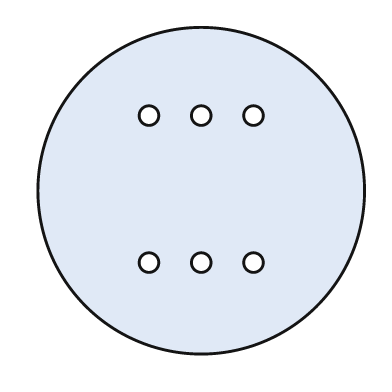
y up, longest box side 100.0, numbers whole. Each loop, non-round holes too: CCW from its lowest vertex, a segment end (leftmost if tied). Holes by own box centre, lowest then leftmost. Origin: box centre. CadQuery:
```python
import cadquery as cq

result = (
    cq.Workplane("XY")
    .moveTo(0.0, 0.0)
    .circle(50.0)
    .moveTo(-16.0, -22.0)
    .circle(3.0)
    .moveTo(0.0, -22.0)
    .circle(3.0)
    .moveTo(16.0, -22.0)
    .circle(3.0)
    .moveTo(-16.0, 23.0)
    .circle(3.0)
    .moveTo(0.0, 23.0)
    .circle(3.0)
    .moveTo(16.0, 23.0)
    .circle(3.0)
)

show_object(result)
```